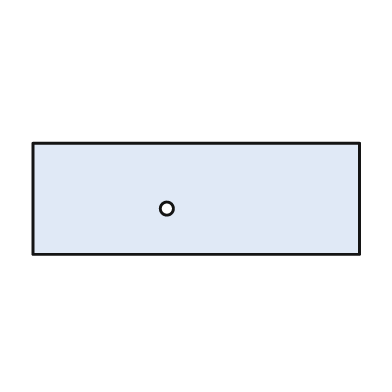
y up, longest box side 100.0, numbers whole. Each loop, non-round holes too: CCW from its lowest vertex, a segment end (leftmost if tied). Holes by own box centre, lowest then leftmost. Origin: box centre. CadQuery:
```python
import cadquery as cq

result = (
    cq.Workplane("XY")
    .moveTo(-50.0, -17.0)
    .lineTo(50.0, -17.0)
    .lineTo(50.0, 17.0)
    .lineTo(-50.0, 17.0)
    .close()
    .moveTo(-9.0, -3.0)
    .circle(2.0)
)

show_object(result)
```